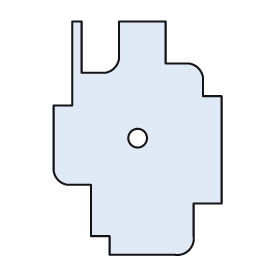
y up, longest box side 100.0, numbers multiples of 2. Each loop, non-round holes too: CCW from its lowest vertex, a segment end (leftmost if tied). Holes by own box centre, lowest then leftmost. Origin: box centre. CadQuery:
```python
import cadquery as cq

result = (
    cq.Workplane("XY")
    .moveTo(-12.0, -50.0)
    .lineTo(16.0, -50.0)
    .threePointArc((22.0, -48.0), (24.0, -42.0))
    .lineTo(24.0, -28.0)
    .lineTo(36.0, -28.0)
    .lineTo(36.0, 18.0)
    .lineTo(28.0, 18.0)
    .lineTo(28.0, 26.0)
    .threePointArc((26.0, 30.0), (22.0, 32.0))
    .lineTo(12.0, 32.0)
    .lineTo(12.0, 50.0)
    .lineTo(-8.0, 50.0)
    .lineTo(-8.0, 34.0)
    .threePointArc((-10.0, 30.0), (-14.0, 28.0))
    .lineTo(-24.0, 28.0)
    .lineTo(-24.0, 50.0)
    .lineTo(-28.0, 50.0)
    .lineTo(-28.0, 14.0)
    .lineTo(-36.0, 14.0)
    .lineTo(-36.0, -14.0)
    .threePointArc((-34.0, -18.0), (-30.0, -20.0))
    .lineTo(-20.0, -20.0)
    .lineTo(-20.0, -42.0)
    .lineTo(-12.0, -42.0)
    .close()
    .moveTo(0.0, 0.0)
    .circle(4.0)
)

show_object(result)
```